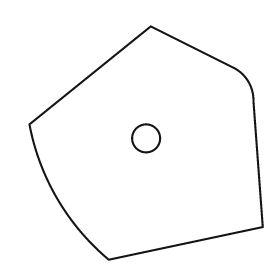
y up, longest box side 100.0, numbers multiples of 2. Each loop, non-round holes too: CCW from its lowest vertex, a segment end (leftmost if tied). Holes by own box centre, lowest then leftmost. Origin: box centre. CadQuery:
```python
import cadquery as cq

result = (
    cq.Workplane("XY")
    .moveTo(-16.0, -50.0)
    .lineTo(50.0, -36.0)
    .lineTo(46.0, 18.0)
    .threePointArc((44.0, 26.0), (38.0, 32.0))
    .lineTo(2.0, 50.0)
    .lineTo(-50.0, 8.0)
    .threePointArc((-38.0, -24.0), (-16.0, -50.0))
    .close()
    .moveTo(0.0, 2.0)
    .circle(6.0)
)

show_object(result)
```